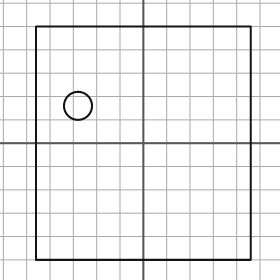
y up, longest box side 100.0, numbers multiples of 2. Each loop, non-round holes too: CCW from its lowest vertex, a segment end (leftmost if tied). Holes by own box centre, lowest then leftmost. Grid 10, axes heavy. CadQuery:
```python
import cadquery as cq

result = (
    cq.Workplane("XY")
    .moveTo(-46.0, -50.0)
    .lineTo(46.0, -50.0)
    .lineTo(46.0, 50.0)
    .lineTo(-46.0, 50.0)
    .close()
    .moveTo(-28.0, 16.0)
    .circle(6.0)
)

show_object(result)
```